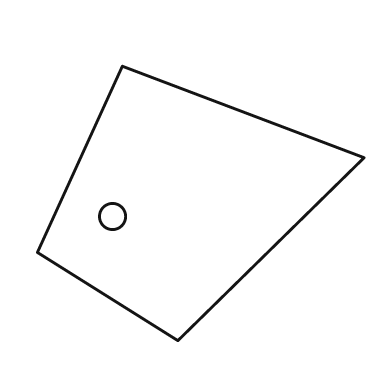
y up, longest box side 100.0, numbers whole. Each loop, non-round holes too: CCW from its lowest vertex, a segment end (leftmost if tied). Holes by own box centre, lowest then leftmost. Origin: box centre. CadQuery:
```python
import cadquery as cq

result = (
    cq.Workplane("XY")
    .moveTo(-7.0, -42.0)
    .lineTo(50.0, 14.0)
    .lineTo(-24.0, 42.0)
    .lineTo(-50.0, -15.0)
    .close()
    .moveTo(-27.0, -4.0)
    .circle(4.0)
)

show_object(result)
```